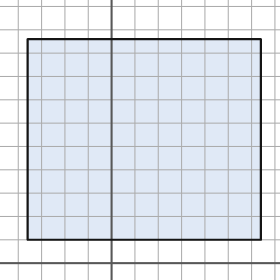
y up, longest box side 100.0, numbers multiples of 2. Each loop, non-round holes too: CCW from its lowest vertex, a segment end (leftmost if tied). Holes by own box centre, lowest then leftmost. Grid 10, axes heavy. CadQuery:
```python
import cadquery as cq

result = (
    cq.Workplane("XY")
    .moveTo(-36.0, 10.0)
    .lineTo(64.0, 10.0)
    .lineTo(64.0, 96.0)
    .lineTo(-36.0, 96.0)
    .close()
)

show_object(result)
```